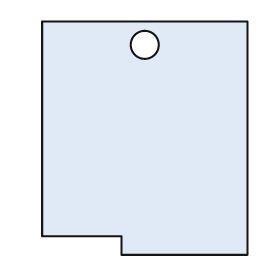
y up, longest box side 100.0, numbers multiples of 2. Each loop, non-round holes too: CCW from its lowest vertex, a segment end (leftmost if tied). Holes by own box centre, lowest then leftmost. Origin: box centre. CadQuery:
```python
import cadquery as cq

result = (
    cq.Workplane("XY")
    .moveTo(-10.0, -50.0)
    .lineTo(44.0, -50.0)
    .lineTo(44.0, 50.0)
    .lineTo(-44.0, 50.0)
    .lineTo(-44.0, -42.0)
    .lineTo(-10.0, -42.0)
    .close()
    .moveTo(0.0, 40.0)
    .circle(6.0)
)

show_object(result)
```